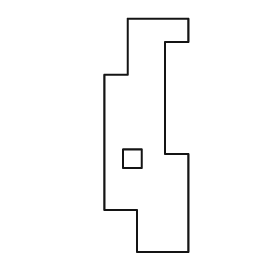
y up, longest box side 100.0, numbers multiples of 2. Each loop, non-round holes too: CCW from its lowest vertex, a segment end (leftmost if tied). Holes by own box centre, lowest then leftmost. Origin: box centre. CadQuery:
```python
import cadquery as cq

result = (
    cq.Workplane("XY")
    .moveTo(-4.0, -50.0)
    .lineTo(18.0, -50.0)
    .lineTo(18.0, -8.0)
    .lineTo(8.0, -8.0)
    .lineTo(8.0, 40.0)
    .lineTo(18.0, 40.0)
    .lineTo(18.0, 50.0)
    .lineTo(-8.0, 50.0)
    .lineTo(-8.0, 26.0)
    .lineTo(-18.0, 26.0)
    .lineTo(-18.0, -32.0)
    .lineTo(-4.0, -32.0)
    .close()
    .moveTo(-10.0, -14.0)
    .lineTo(-2.0, -14.0)
    .lineTo(-2.0, -6.0)
    .lineTo(-10.0, -6.0)
    .close()
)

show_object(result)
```